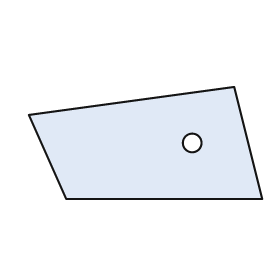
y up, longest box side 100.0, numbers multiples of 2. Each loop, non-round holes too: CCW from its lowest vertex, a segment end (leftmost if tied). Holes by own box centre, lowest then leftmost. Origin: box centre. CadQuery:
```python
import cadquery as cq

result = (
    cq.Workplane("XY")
    .moveTo(-34.0, -24.0)
    .lineTo(50.0, -24.0)
    .lineTo(38.0, 24.0)
    .lineTo(-50.0, 12.0)
    .close()
    .moveTo(20.0, 0.0)
    .circle(4.0)
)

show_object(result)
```